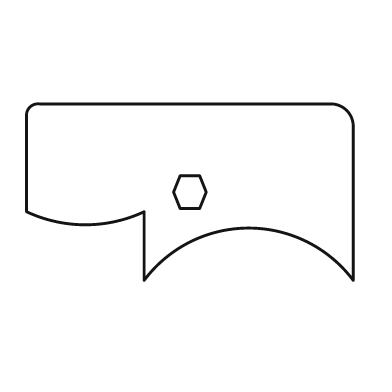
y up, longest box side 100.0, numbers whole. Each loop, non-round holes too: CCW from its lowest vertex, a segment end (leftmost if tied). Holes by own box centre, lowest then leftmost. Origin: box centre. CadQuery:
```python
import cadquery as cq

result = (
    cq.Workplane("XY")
    .moveTo(-14.0, -27.0)
    .threePointArc((18.0, -11.0), (50.0, -27.0))
    .lineTo(50.0, 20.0)
    .threePointArc((48.0, 25.0), (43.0, 27.0))
    .lineTo(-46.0, 27.0)
    .threePointArc((-49.0, 26.0), (-50.0, 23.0))
    .lineTo(-50.0, -6.0)
    .threePointArc((-32.0, -10.0), (-14.0, -6.0))
    .close()
    .moveTo(-3.0, -5.0)
    .lineTo(3.0, -5.0)
    .lineTo(5.0, 0.0)
    .lineTo(3.0, 5.0)
    .lineTo(-3.0, 5.0)
    .lineTo(-5.0, 0.0)
    .close()
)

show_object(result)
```